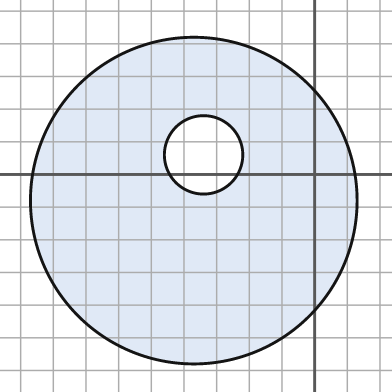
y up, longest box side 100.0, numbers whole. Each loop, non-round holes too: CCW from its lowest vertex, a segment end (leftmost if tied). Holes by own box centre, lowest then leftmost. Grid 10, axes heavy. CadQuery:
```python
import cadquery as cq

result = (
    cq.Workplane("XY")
    .moveTo(-37.0, -8.0)
    .circle(50.0)
    .moveTo(-34.0, 6.0)
    .circle(12.0)
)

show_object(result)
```